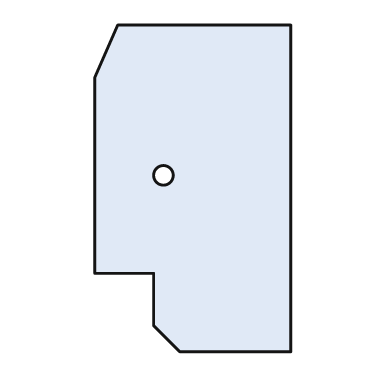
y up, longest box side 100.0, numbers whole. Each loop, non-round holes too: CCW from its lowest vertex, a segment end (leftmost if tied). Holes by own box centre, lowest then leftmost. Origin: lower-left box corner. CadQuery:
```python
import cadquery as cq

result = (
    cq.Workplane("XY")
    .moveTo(26.0, 0.0)
    .lineTo(60.0, 0.0)
    .lineTo(60.0, 100.0)
    .lineTo(7.0, 100.0)
    .lineTo(0.0, 84.0)
    .lineTo(0.0, 24.0)
    .lineTo(18.0, 24.0)
    .lineTo(18.0, 8.0)
    .close()
    .moveTo(21.0, 54.0)
    .circle(3.0)
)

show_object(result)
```